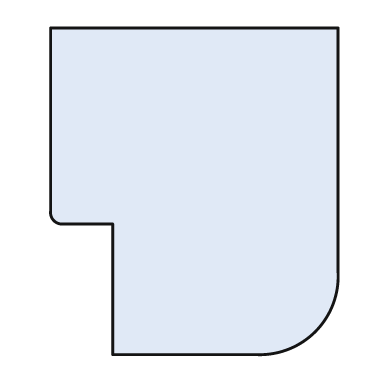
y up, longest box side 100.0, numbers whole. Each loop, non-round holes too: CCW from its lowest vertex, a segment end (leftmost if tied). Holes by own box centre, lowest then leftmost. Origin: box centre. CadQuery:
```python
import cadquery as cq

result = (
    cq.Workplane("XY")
    .moveTo(-25.0, -50.0)
    .lineTo(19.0, -50.0)
    .threePointArc((37.0, -43.0), (44.0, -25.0))
    .lineTo(44.0, 50.0)
    .lineTo(-44.0, 50.0)
    .lineTo(-44.0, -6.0)
    .threePointArc((-43.0, -9.0), (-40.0, -10.0))
    .lineTo(-25.0, -10.0)
    .close()
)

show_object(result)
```